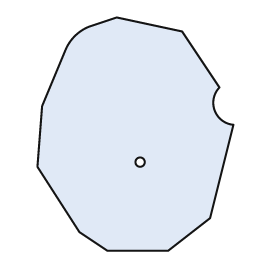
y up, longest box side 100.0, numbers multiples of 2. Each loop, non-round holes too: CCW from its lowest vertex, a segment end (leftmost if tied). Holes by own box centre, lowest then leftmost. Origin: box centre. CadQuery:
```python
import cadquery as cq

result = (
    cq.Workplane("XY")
    .moveTo(-12.0, -50.0)
    .lineTo(14.0, -50.0)
    .lineTo(32.0, -36.0)
    .lineTo(42.0, 4.0)
    .threePointArc((34.0, 10.0), (36.0, 20.0))
    .lineTo(20.0, 44.0)
    .lineTo(-8.0, 50.0)
    .lineTo(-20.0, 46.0)
    .threePointArc((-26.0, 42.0), (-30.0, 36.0))
    .lineTo(-40.0, 12.0)
    .lineTo(-42.0, -14.0)
    .lineTo(-24.0, -42.0)
    .close()
    .moveTo(2.0, -12.0)
    .circle(2.0)
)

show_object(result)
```